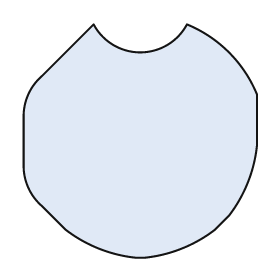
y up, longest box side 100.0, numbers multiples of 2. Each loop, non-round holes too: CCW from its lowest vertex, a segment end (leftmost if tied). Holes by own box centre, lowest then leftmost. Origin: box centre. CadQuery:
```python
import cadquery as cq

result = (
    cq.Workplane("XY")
    .moveTo(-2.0, -50.0)
    .lineTo(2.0, -50.0)
    .threePointArc((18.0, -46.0), (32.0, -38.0))
    .lineTo(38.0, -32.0)
    .threePointArc((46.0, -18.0), (50.0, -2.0))
    .lineTo(50.0, 20.0)
    .threePointArc((38.0, 38.0), (20.0, 50.0))
    .threePointArc((0.0, 38.0), (-20.0, 50.0))
    .lineTo(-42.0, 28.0)
    .threePointArc((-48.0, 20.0), (-50.0, 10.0))
    .lineTo(-50.0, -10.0)
    .threePointArc((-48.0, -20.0), (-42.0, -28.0))
    .lineTo(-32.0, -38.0)
    .threePointArc((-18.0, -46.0), (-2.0, -50.0))
    .close()
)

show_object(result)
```